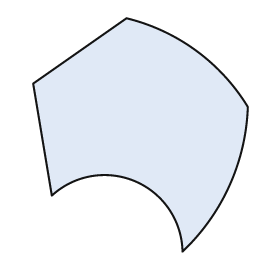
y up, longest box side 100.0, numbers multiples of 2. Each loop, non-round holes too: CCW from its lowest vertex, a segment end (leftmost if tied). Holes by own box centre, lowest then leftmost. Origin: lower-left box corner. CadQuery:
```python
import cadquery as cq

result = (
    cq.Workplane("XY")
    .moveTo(64.0, 0.0)
    .threePointArc((84.0, 28.0), (92.0, 62.0))
    .threePointArc((70.0, 86.0), (40.0, 100.0))
    .lineTo(0.0, 72.0)
    .lineTo(8.0, 24.0)
    .threePointArc((44.0, 30.0), (64.0, 0.0))
    .close()
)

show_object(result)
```